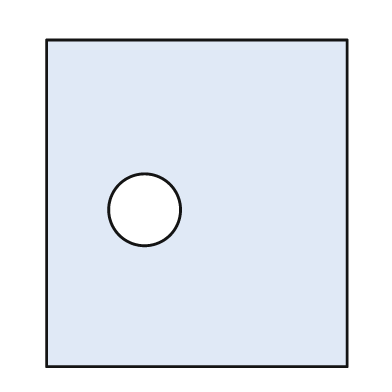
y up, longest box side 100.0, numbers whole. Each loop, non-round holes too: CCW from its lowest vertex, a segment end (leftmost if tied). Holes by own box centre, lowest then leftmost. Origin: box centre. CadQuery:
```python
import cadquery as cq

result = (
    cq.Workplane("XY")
    .moveTo(-46.0, -50.0)
    .lineTo(46.0, -50.0)
    .lineTo(46.0, 50.0)
    .lineTo(-46.0, 50.0)
    .close()
    .moveTo(-16.0, -2.0)
    .circle(11.0)
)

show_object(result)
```